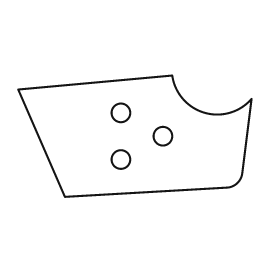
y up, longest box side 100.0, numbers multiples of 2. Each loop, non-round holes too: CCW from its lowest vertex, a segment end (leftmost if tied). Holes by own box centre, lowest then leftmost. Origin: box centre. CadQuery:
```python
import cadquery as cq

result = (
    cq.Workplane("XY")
    .moveTo(-30.0, -26.0)
    .lineTo(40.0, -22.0)
    .threePointArc((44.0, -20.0), (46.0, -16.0))
    .lineTo(50.0, 16.0)
    .threePointArc((30.0, 10.0), (16.0, 26.0))
    .lineTo(-50.0, 20.0)
    .close()
    .moveTo(-6.0, -10.0)
    .circle(4.0)
    .moveTo(12.0, 0.0)
    .circle(4.0)
    .moveTo(-6.0, 10.0)
    .circle(4.0)
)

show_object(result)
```